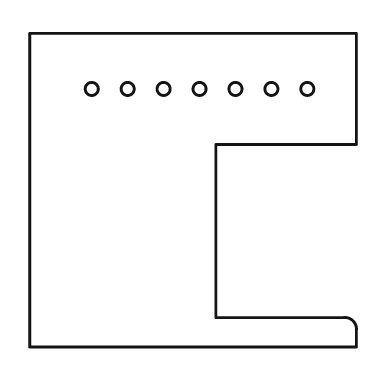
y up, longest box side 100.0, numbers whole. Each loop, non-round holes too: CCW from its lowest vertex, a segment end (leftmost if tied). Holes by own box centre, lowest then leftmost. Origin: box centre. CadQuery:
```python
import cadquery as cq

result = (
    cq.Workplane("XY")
    .moveTo(-50.0, -48.0)
    .lineTo(50.0, -48.0)
    .lineTo(50.0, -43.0)
    .threePointArc((49.0, -40.0), (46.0, -39.0))
    .lineTo(7.0, -39.0)
    .lineTo(7.0, 14.0)
    .lineTo(50.0, 14.0)
    .lineTo(50.0, 48.0)
    .lineTo(-50.0, 48.0)
    .close()
    .moveTo(-31.0, 31.0)
    .circle(2.0)
    .moveTo(-20.0, 31.0)
    .circle(2.0)
    .moveTo(-9.0, 31.0)
    .circle(2.0)
    .moveTo(2.0, 31.0)
    .circle(2.0)
    .moveTo(13.0, 31.0)
    .circle(2.0)
    .moveTo(24.0, 31.0)
    .circle(2.0)
    .moveTo(35.0, 31.0)
    .circle(2.0)
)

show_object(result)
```